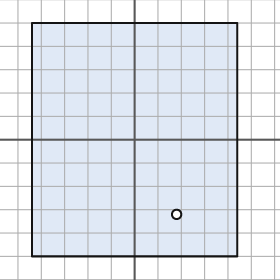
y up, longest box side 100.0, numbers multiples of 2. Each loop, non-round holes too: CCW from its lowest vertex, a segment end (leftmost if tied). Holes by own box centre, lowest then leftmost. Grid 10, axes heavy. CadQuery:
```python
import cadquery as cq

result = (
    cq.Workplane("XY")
    .moveTo(-44.0, -50.0)
    .lineTo(44.0, -50.0)
    .lineTo(44.0, 50.0)
    .lineTo(-44.0, 50.0)
    .close()
    .moveTo(18.0, -32.0)
    .circle(2.0)
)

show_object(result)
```